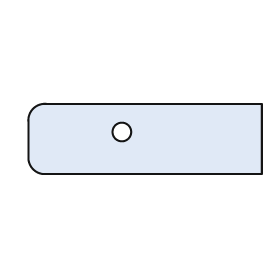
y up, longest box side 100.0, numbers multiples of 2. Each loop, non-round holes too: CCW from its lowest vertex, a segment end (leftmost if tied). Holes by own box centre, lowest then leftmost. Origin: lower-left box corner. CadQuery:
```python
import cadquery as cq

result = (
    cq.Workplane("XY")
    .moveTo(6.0, 0.0)
    .lineTo(100.0, 0.0)
    .lineTo(100.0, 30.0)
    .lineTo(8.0, 30.0)
    .threePointArc((2.0, 28.0), (0.0, 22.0))
    .lineTo(0.0, 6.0)
    .threePointArc((2.0, 2.0), (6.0, 0.0))
    .close()
    .moveTo(40.0, 18.0)
    .circle(4.0)
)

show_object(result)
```